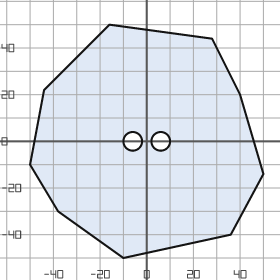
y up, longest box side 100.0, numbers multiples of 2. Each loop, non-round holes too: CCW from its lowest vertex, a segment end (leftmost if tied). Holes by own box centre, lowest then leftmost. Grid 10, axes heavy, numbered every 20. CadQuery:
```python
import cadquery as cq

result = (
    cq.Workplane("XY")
    .moveTo(-10.0, -50.0)
    .lineTo(36.0, -40.0)
    .lineTo(50.0, -14.0)
    .lineTo(40.0, 20.0)
    .lineTo(28.0, 44.0)
    .lineTo(-16.0, 50.0)
    .lineTo(-44.0, 22.0)
    .lineTo(-50.0, -10.0)
    .lineTo(-38.0, -30.0)
    .close()
    .moveTo(-6.0, 0.0)
    .circle(4.0)
    .moveTo(6.0, 0.0)
    .circle(4.0)
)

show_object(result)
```